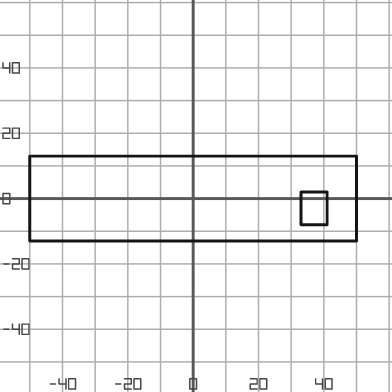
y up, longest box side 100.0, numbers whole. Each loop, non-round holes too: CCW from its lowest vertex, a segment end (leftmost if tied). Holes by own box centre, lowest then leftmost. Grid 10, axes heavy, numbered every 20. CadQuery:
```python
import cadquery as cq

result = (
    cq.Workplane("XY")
    .moveTo(-50.0, -13.0)
    .lineTo(50.0, -13.0)
    .lineTo(50.0, 13.0)
    .lineTo(-50.0, 13.0)
    .close()
    .moveTo(33.0, -8.0)
    .lineTo(41.0, -8.0)
    .lineTo(41.0, 2.0)
    .lineTo(33.0, 2.0)
    .close()
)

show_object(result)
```